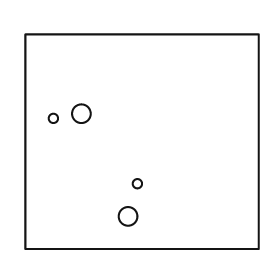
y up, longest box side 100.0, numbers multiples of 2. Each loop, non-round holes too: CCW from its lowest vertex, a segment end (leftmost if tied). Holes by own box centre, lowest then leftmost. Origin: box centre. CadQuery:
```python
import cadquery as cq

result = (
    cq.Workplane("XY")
    .moveTo(-50.0, -46.0)
    .lineTo(50.0, -46.0)
    .lineTo(50.0, 46.0)
    .lineTo(-50.0, 46.0)
    .close()
    .moveTo(-6.0, -32.0)
    .circle(4.0)
    .moveTo(-2.0, -18.0)
    .circle(2.0)
    .moveTo(-38.0, 10.0)
    .circle(2.0)
    .moveTo(-26.0, 12.0)
    .circle(4.0)
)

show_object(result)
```